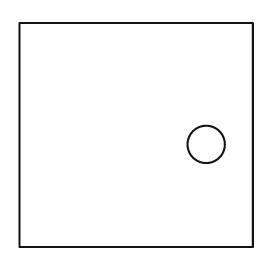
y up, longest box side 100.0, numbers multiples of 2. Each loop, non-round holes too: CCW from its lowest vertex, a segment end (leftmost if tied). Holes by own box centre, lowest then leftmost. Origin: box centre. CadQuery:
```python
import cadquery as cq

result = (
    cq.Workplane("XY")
    .moveTo(-50.0, -48.0)
    .lineTo(50.0, -48.0)
    .lineTo(50.0, 48.0)
    .lineTo(-50.0, 48.0)
    .close()
    .moveTo(30.0, -4.0)
    .circle(8.0)
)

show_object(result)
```